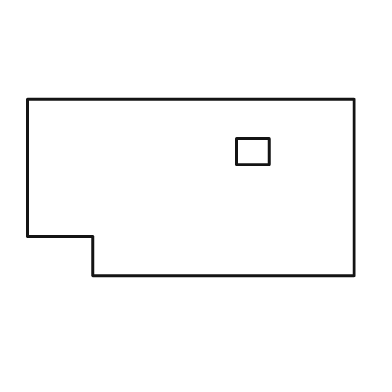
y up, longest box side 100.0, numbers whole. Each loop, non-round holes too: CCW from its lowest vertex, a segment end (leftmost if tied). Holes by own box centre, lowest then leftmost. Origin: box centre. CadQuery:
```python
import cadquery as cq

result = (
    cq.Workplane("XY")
    .moveTo(-30.0, -27.0)
    .lineTo(50.0, -27.0)
    .lineTo(50.0, 27.0)
    .lineTo(-50.0, 27.0)
    .lineTo(-50.0, -15.0)
    .lineTo(-30.0, -15.0)
    .close()
    .moveTo(14.0, 7.0)
    .lineTo(24.0, 7.0)
    .lineTo(24.0, 15.0)
    .lineTo(14.0, 15.0)
    .close()
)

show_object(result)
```